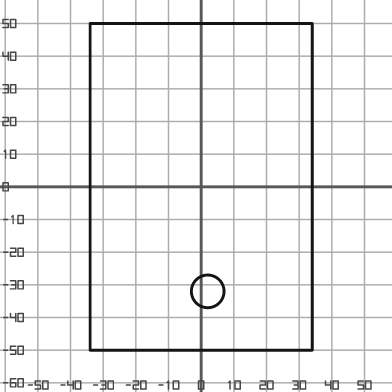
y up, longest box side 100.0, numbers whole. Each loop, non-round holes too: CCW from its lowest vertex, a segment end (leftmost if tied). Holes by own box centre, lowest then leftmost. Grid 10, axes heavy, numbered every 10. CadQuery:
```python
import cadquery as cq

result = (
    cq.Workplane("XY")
    .moveTo(-34.0, -50.0)
    .lineTo(34.0, -50.0)
    .lineTo(34.0, 50.0)
    .lineTo(-34.0, 50.0)
    .close()
    .moveTo(2.0, -32.0)
    .circle(5.0)
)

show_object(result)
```